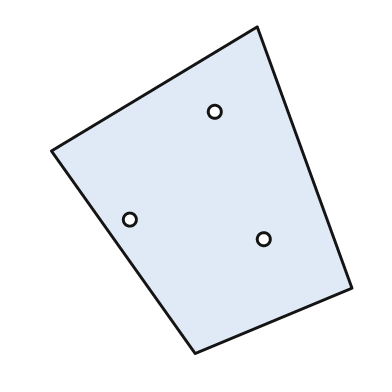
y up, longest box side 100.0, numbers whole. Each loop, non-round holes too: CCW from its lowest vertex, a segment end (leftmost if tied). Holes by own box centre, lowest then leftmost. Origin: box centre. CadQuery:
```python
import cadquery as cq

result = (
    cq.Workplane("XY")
    .moveTo(-2.0, -50.0)
    .lineTo(46.0, -30.0)
    .lineTo(17.0, 50.0)
    .lineTo(-46.0, 12.0)
    .close()
    .moveTo(19.0, -15.0)
    .circle(2.0)
    .moveTo(-22.0, -9.0)
    .circle(2.0)
    .moveTo(4.0, 24.0)
    .circle(2.0)
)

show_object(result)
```